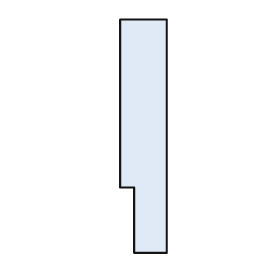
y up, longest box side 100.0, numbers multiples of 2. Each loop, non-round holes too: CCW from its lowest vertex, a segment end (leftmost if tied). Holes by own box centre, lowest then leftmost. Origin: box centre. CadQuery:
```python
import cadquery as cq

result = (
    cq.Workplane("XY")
    .moveTo(-4.0, -50.0)
    .lineTo(10.0, -50.0)
    .lineTo(10.0, 50.0)
    .lineTo(-10.0, 50.0)
    .lineTo(-10.0, -22.0)
    .lineTo(-4.0, -22.0)
    .close()
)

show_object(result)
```